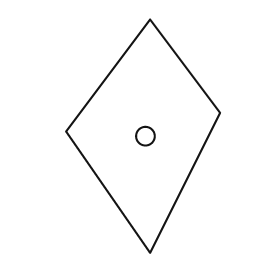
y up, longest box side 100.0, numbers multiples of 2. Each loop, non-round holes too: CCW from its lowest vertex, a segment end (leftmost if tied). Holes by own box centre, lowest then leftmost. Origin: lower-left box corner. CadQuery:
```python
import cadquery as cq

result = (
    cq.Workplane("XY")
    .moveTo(36.0, 0.0)
    .lineTo(66.0, 60.0)
    .lineTo(36.0, 100.0)
    .lineTo(0.0, 52.0)
    .close()
    .moveTo(34.0, 50.0)
    .circle(4.0)
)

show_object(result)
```